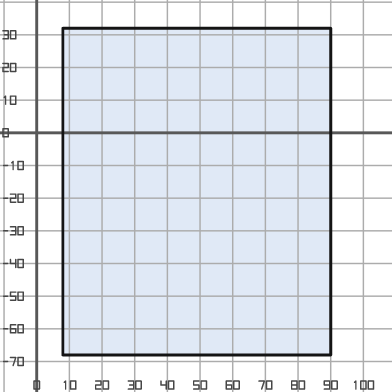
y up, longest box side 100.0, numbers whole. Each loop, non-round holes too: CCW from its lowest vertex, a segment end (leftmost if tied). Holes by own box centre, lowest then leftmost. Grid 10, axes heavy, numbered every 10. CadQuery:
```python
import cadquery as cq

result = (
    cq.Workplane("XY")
    .moveTo(8.0, -68.0)
    .lineTo(90.0, -68.0)
    .lineTo(90.0, 32.0)
    .lineTo(8.0, 32.0)
    .close()
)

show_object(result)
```